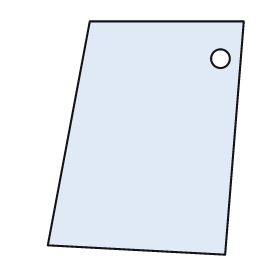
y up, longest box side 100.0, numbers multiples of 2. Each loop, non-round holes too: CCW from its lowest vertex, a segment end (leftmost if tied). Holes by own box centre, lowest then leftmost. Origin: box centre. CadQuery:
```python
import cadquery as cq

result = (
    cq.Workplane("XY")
    .moveTo(34.0, -50.0)
    .lineTo(42.0, 50.0)
    .lineTo(-24.0, 50.0)
    .lineTo(-42.0, -46.0)
    .close()
    .moveTo(32.0, 34.0)
    .circle(4.0)
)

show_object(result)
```